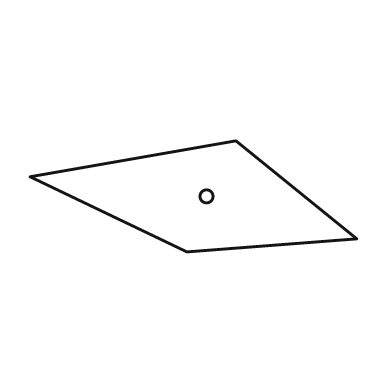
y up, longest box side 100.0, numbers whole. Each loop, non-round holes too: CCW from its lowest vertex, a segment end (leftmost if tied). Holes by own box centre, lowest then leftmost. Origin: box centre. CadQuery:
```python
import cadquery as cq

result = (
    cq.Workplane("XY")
    .moveTo(-2.0, -17.0)
    .lineTo(50.0, -13.0)
    .lineTo(13.0, 17.0)
    .lineTo(-50.0, 6.0)
    .close()
    .moveTo(4.0, 0.0)
    .circle(2.0)
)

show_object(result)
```